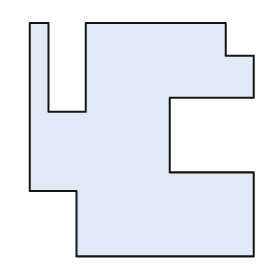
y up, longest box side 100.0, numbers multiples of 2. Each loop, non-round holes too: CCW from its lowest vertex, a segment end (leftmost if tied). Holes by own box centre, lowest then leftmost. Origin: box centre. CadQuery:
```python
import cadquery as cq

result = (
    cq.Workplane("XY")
    .moveTo(-28.0, -50.0)
    .lineTo(48.0, -50.0)
    .lineTo(48.0, -14.0)
    .lineTo(12.0, -14.0)
    .lineTo(12.0, 18.0)
    .lineTo(48.0, 18.0)
    .lineTo(48.0, 36.0)
    .lineTo(36.0, 36.0)
    .lineTo(36.0, 50.0)
    .lineTo(-24.0, 50.0)
    .lineTo(-24.0, 12.0)
    .lineTo(-40.0, 12.0)
    .lineTo(-40.0, 50.0)
    .lineTo(-48.0, 50.0)
    .lineTo(-48.0, -22.0)
    .lineTo(-28.0, -22.0)
    .close()
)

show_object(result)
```